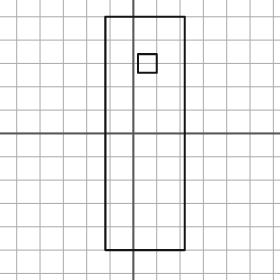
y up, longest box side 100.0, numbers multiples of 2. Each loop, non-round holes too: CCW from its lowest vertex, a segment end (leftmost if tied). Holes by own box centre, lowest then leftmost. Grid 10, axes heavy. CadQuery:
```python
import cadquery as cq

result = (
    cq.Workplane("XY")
    .moveTo(-12.0, -50.0)
    .lineTo(22.0, -50.0)
    .lineTo(22.0, 50.0)
    .lineTo(-12.0, 50.0)
    .close()
    .moveTo(2.0, 26.0)
    .lineTo(10.0, 26.0)
    .lineTo(10.0, 34.0)
    .lineTo(2.0, 34.0)
    .close()
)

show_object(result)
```